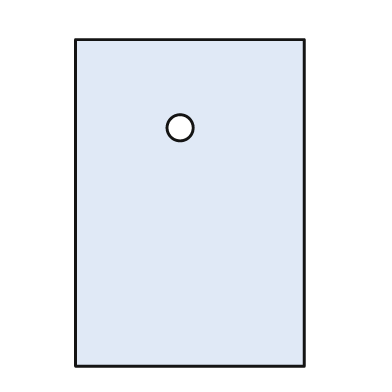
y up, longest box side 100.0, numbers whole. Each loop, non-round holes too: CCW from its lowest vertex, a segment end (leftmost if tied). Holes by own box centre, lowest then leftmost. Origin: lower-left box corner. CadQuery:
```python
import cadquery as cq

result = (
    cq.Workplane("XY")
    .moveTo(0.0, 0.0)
    .lineTo(70.0, 0.0)
    .lineTo(70.0, 100.0)
    .lineTo(0.0, 100.0)
    .close()
    .moveTo(32.0, 73.0)
    .circle(4.0)
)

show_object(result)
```